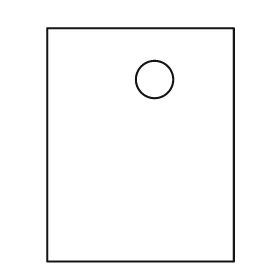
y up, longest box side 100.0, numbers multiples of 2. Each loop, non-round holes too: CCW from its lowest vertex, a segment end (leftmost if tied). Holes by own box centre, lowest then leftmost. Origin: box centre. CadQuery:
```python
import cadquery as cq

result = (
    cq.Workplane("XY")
    .moveTo(-40.0, -50.0)
    .lineTo(40.0, -50.0)
    .lineTo(40.0, 50.0)
    .lineTo(-40.0, 50.0)
    .close()
    .moveTo(6.0, 28.0)
    .circle(8.0)
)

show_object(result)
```